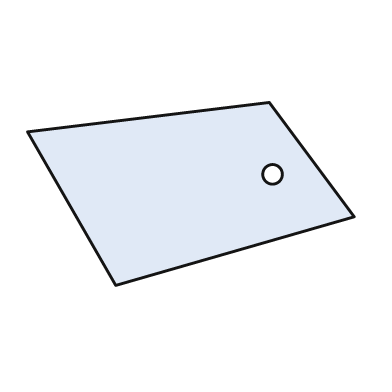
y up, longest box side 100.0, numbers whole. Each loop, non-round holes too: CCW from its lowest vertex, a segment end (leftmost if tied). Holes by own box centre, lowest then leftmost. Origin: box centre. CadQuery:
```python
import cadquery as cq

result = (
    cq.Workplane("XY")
    .moveTo(-23.0, -28.0)
    .lineTo(50.0, -7.0)
    .lineTo(24.0, 28.0)
    .lineTo(-50.0, 19.0)
    .close()
    .moveTo(25.0, 6.0)
    .circle(3.0)
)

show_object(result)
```